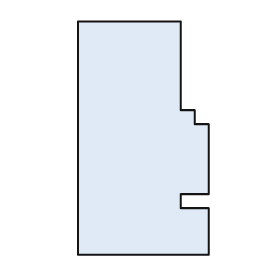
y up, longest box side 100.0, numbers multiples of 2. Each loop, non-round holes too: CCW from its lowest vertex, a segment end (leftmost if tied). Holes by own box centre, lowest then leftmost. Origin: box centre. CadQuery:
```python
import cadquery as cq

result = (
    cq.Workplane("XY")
    .moveTo(-28.0, -50.0)
    .lineTo(28.0, -50.0)
    .lineTo(28.0, -30.0)
    .lineTo(16.0, -30.0)
    .lineTo(16.0, -24.0)
    .lineTo(28.0, -24.0)
    .lineTo(28.0, 6.0)
    .lineTo(22.0, 6.0)
    .lineTo(22.0, 12.0)
    .lineTo(16.0, 12.0)
    .lineTo(16.0, 50.0)
    .lineTo(-28.0, 50.0)
    .close()
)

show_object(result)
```